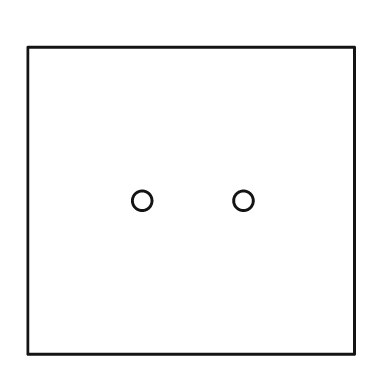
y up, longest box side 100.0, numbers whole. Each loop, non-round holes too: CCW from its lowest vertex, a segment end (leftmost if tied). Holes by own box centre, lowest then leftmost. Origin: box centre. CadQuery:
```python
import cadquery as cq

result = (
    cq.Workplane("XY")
    .moveTo(-50.0, -47.0)
    .lineTo(50.0, -47.0)
    .lineTo(50.0, 47.0)
    .lineTo(-50.0, 47.0)
    .close()
    .moveTo(-15.0, 0.0)
    .circle(3.0)
    .moveTo(16.0, 0.0)
    .circle(3.0)
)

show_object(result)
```